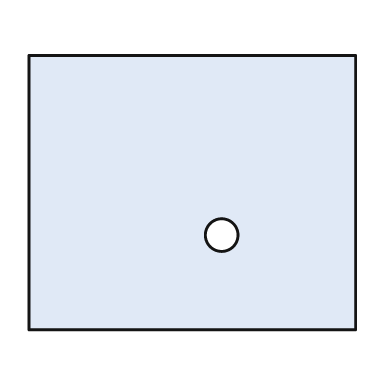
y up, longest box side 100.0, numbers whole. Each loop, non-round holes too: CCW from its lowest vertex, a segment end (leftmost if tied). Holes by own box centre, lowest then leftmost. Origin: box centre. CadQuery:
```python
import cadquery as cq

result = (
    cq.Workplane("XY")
    .moveTo(-50.0, -42.0)
    .lineTo(50.0, -42.0)
    .lineTo(50.0, 42.0)
    .lineTo(-50.0, 42.0)
    .close()
    .moveTo(9.0, -13.0)
    .circle(5.0)
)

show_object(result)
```